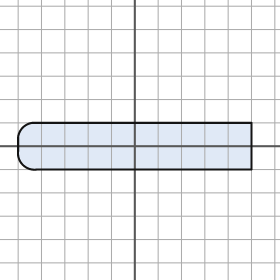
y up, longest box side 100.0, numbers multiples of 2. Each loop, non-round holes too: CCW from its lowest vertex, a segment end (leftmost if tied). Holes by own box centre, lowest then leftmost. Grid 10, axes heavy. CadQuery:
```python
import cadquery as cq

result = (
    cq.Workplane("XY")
    .moveTo(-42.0, -10.0)
    .lineTo(50.0, -10.0)
    .lineTo(50.0, 10.0)
    .lineTo(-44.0, 10.0)
    .threePointArc((-48.0, 8.0), (-50.0, 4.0))
    .lineTo(-50.0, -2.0)
    .threePointArc((-48.0, -8.0), (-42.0, -10.0))
    .close()
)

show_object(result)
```